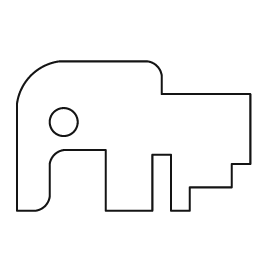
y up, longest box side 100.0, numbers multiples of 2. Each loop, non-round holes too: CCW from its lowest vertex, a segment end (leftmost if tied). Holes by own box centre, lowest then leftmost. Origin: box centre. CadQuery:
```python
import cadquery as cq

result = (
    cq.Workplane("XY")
    .moveTo(-50.0, -32.0)
    .lineTo(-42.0, -32.0)
    .threePointArc((-38.0, -30.0), (-36.0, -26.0))
    .lineTo(-36.0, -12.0)
    .threePointArc((-34.0, -8.0), (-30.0, -6.0))
    .lineTo(-12.0, -6.0)
    .lineTo(-12.0, -32.0)
    .lineTo(8.0, -32.0)
    .lineTo(8.0, -8.0)
    .lineTo(16.0, -8.0)
    .lineTo(16.0, -32.0)
    .lineTo(24.0, -32.0)
    .lineTo(24.0, -22.0)
    .lineTo(42.0, -22.0)
    .lineTo(42.0, -12.0)
    .lineTo(50.0, -12.0)
    .lineTo(50.0, 18.0)
    .lineTo(12.0, 18.0)
    .lineTo(12.0, 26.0)
    .threePointArc((10.0, 30.0), (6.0, 32.0))
    .lineTo(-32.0, 32.0)
    .threePointArc((-44.0, 26.0), (-50.0, 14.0))
    .close()
    .moveTo(-30.0, 6.0)
    .circle(6.0)
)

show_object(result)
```